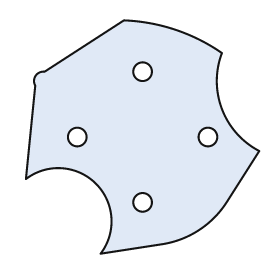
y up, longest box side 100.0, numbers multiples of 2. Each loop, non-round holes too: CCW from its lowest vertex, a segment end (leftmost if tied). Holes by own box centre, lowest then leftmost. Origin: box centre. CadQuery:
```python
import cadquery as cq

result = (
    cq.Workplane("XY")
    .moveTo(-18.0, -50.0)
    .lineTo(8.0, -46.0)
    .threePointArc((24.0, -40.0), (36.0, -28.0))
    .lineTo(50.0, -6.0)
    .threePointArc((34.0, 12.0), (34.0, 36.0))
    .threePointArc((14.0, 46.0), (-8.0, 50.0))
    .lineTo(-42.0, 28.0)
    .threePointArc((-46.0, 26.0), (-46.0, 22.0))
    .lineTo(-50.0, -18.0)
    .threePointArc((-20.0, -20.0), (-18.0, -50.0))
    .close()
    .moveTo(0.0, -28.0)
    .circle(4.0)
    .moveTo(-28.0, 0.0)
    .circle(4.0)
    .moveTo(28.0, 0.0)
    .circle(4.0)
    .moveTo(0.0, 28.0)
    .circle(4.0)
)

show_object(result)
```